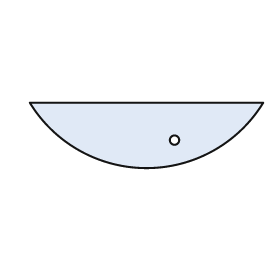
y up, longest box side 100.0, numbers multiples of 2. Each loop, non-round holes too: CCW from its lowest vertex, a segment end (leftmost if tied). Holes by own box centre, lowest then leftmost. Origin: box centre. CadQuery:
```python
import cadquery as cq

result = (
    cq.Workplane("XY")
    .moveTo(-50.0, 14.0)
    .threePointArc((0.0, -14.0), (50.0, 14.0))
    .close()
    .moveTo(12.0, -2.0)
    .circle(2.0)
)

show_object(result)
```